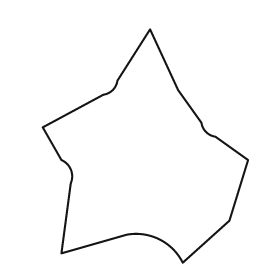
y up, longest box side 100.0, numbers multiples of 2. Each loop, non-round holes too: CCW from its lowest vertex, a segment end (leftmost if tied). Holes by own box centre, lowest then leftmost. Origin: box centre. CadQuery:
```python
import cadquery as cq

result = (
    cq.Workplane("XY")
    .moveTo(16.0, -50.0)
    .lineTo(36.0, -32.0)
    .lineTo(44.0, -6.0)
    .lineTo(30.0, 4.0)
    .threePointArc((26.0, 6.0), (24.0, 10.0))
    .lineTo(14.0, 24.0)
    .lineTo(2.0, 50.0)
    .lineTo(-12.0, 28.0)
    .threePointArc((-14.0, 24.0), (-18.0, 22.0))
    .lineTo(-44.0, 8.0)
    .lineTo(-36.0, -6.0)
    .threePointArc((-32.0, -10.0), (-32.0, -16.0))
    .lineTo(-36.0, -46.0)
    .lineTo(-8.0, -38.0)
    .threePointArc((6.0, -40.0), (16.0, -50.0))
    .close()
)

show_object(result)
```